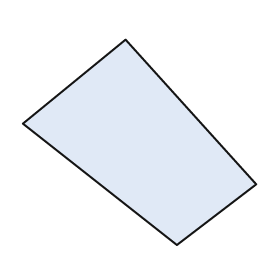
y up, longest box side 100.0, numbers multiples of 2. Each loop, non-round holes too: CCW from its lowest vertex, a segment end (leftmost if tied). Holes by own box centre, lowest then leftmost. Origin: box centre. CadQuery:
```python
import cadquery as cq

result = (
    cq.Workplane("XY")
    .moveTo(16.0, -44.0)
    .lineTo(50.0, -18.0)
    .lineTo(-6.0, 44.0)
    .lineTo(-50.0, 8.0)
    .close()
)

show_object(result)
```